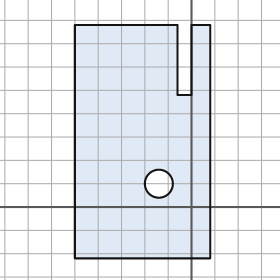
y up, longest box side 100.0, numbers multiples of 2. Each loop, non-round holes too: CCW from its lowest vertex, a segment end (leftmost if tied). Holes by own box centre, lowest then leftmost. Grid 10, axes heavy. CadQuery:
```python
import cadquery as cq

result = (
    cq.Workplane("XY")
    .moveTo(-50.0, -22.0)
    .lineTo(8.0, -22.0)
    .lineTo(8.0, 78.0)
    .lineTo(0.0, 78.0)
    .lineTo(0.0, 48.0)
    .lineTo(-6.0, 48.0)
    .lineTo(-6.0, 78.0)
    .lineTo(-50.0, 78.0)
    .close()
    .moveTo(-14.0, 10.0)
    .circle(6.0)
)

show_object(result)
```